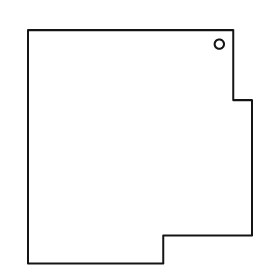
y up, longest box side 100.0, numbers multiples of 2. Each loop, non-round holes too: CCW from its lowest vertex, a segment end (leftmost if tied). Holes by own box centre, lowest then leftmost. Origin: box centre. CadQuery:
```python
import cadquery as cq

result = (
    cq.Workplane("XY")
    .moveTo(-48.0, -50.0)
    .lineTo(10.0, -50.0)
    .lineTo(10.0, -38.0)
    .lineTo(48.0, -38.0)
    .lineTo(48.0, 20.0)
    .lineTo(40.0, 20.0)
    .lineTo(40.0, 50.0)
    .lineTo(-48.0, 50.0)
    .close()
    .moveTo(34.0, 44.0)
    .circle(2.0)
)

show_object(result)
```